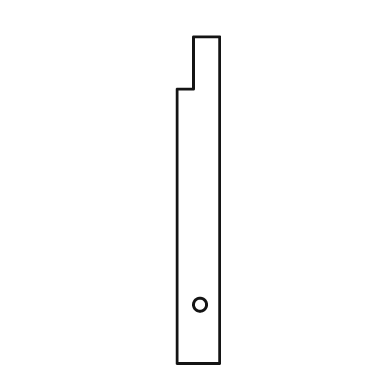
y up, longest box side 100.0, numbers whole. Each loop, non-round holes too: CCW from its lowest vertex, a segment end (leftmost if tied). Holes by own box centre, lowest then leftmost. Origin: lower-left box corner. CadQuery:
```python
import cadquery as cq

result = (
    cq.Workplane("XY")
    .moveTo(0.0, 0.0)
    .lineTo(13.0, 0.0)
    .lineTo(13.0, 100.0)
    .lineTo(5.0, 100.0)
    .lineTo(5.0, 84.0)
    .lineTo(0.0, 84.0)
    .close()
    .moveTo(7.0, 18.0)
    .circle(2.0)
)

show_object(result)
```